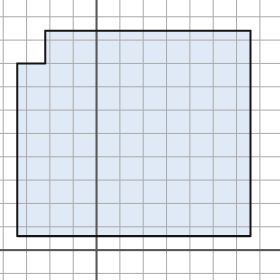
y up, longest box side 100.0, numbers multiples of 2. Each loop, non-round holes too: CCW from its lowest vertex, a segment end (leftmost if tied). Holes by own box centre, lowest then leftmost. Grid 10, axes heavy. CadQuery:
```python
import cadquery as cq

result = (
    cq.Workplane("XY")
    .moveTo(-34.0, 6.0)
    .lineTo(66.0, 6.0)
    .lineTo(66.0, 94.0)
    .lineTo(-22.0, 94.0)
    .lineTo(-22.0, 80.0)
    .lineTo(-34.0, 80.0)
    .close()
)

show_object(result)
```